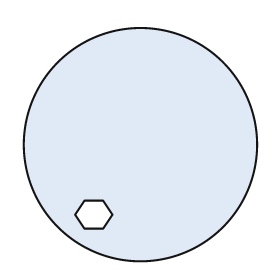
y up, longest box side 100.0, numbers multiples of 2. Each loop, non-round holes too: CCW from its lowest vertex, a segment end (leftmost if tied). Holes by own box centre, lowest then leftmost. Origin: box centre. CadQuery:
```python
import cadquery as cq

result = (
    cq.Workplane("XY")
    .moveTo(0.0, 0.0)
    .circle(50.0)
    .moveTo(-24.0, -36.0)
    .lineTo(-16.0, -36.0)
    .lineTo(-12.0, -30.0)
    .lineTo(-16.0, -24.0)
    .lineTo(-24.0, -24.0)
    .lineTo(-28.0, -30.0)
    .close()
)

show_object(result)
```